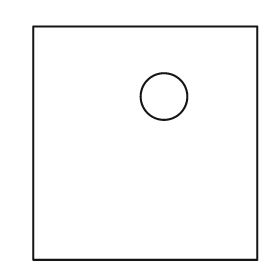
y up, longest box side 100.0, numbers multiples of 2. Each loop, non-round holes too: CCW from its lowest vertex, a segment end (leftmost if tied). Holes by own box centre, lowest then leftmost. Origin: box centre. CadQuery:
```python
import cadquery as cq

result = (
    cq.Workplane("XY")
    .moveTo(-48.0, -50.0)
    .lineTo(48.0, -50.0)
    .lineTo(48.0, 50.0)
    .lineTo(-48.0, 50.0)
    .close()
    .moveTo(8.0, 20.0)
    .circle(10.0)
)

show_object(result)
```